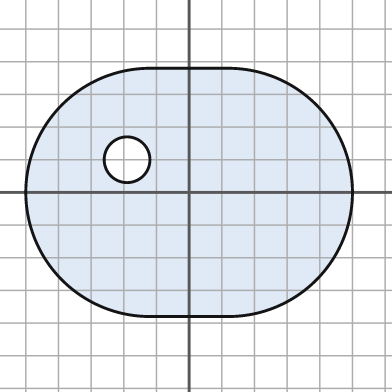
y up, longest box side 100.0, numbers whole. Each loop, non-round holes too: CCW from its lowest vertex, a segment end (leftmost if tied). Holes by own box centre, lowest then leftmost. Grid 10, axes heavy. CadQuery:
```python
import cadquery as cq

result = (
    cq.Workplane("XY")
    .moveTo(-12.0, -38.0)
    .lineTo(12.0, -38.0)
    .threePointArc((50.0, 0.0), (12.0, 38.0))
    .lineTo(-12.0, 38.0)
    .threePointArc((-50.0, 0.0), (-12.0, -38.0))
    .close()
    .moveTo(-19.0, 10.0)
    .circle(7.0)
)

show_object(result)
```